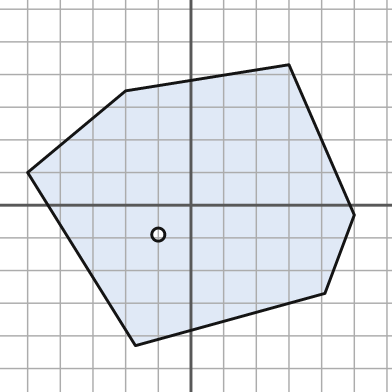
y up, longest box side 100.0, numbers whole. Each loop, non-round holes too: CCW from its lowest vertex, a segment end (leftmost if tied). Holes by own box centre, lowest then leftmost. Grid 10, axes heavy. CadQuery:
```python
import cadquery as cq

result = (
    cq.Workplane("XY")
    .moveTo(-17.0, -43.0)
    .lineTo(41.0, -27.0)
    .lineTo(50.0, -3.0)
    .lineTo(30.0, 43.0)
    .lineTo(-20.0, 35.0)
    .lineTo(-50.0, 10.0)
    .close()
    .moveTo(-10.0, -9.0)
    .circle(2.0)
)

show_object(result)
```